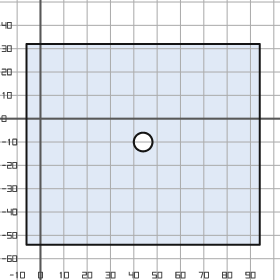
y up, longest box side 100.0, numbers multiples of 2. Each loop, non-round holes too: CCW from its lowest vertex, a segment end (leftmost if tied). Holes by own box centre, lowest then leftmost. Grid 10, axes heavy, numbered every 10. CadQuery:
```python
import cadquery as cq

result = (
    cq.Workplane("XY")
    .moveTo(-6.0, -54.0)
    .lineTo(94.0, -54.0)
    .lineTo(94.0, 32.0)
    .lineTo(-6.0, 32.0)
    .close()
    .moveTo(44.0, -10.0)
    .circle(4.0)
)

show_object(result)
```